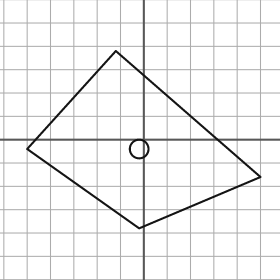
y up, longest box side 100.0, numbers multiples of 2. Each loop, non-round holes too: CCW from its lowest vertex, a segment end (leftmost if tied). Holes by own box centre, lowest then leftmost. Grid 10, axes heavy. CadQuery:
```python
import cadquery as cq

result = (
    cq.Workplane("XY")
    .moveTo(-2.0, -38.0)
    .lineTo(50.0, -16.0)
    .lineTo(-12.0, 38.0)
    .lineTo(-50.0, -4.0)
    .close()
    .moveTo(-2.0, -4.0)
    .circle(4.0)
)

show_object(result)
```